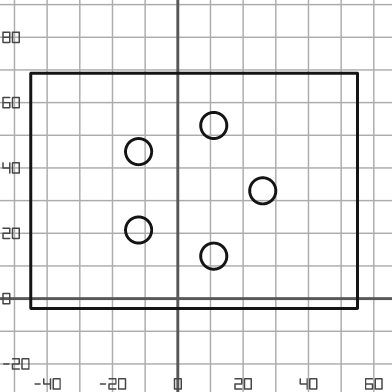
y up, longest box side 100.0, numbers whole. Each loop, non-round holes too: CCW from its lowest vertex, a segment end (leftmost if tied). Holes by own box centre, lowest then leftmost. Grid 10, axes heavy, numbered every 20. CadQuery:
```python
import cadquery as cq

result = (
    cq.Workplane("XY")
    .moveTo(-45.0, -3.0)
    .lineTo(55.0, -3.0)
    .lineTo(55.0, 69.0)
    .lineTo(-45.0, 69.0)
    .close()
    .moveTo(11.0, 13.0)
    .circle(4.0)
    .moveTo(-12.0, 21.0)
    .circle(4.0)
    .moveTo(26.0, 33.0)
    .circle(4.0)
    .moveTo(-12.0, 45.0)
    .circle(4.0)
    .moveTo(11.0, 53.0)
    .circle(4.0)
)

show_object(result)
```